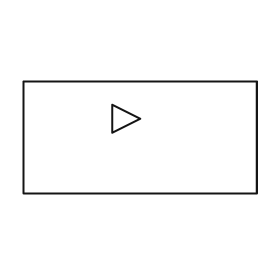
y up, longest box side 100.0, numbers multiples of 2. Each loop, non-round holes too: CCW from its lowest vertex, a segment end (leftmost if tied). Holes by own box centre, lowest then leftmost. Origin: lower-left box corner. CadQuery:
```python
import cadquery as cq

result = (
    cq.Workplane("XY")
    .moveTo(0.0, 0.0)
    .lineTo(100.0, 0.0)
    .lineTo(100.0, 48.0)
    .lineTo(0.0, 48.0)
    .close()
    .moveTo(38.0, 26.0)
    .lineTo(50.0, 32.0)
    .lineTo(38.0, 38.0)
    .close()
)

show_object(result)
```